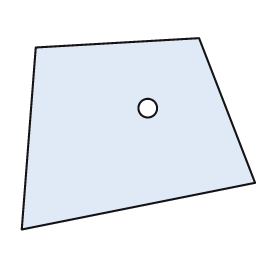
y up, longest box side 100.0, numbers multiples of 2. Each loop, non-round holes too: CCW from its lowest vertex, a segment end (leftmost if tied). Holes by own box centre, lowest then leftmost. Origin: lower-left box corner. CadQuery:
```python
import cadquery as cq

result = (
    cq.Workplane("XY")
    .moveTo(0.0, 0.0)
    .lineTo(100.0, 20.0)
    .lineTo(76.0, 82.0)
    .lineTo(6.0, 78.0)
    .close()
    .moveTo(54.0, 52.0)
    .circle(4.0)
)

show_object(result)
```